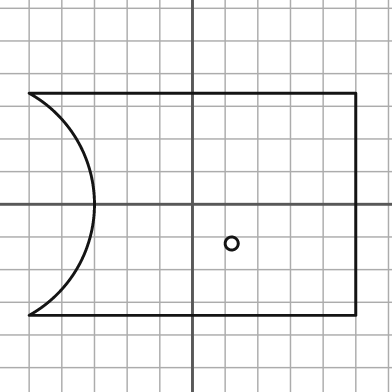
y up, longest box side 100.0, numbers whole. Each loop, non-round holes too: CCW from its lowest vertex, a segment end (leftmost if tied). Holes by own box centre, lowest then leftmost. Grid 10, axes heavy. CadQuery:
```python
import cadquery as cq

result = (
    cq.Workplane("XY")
    .moveTo(-50.0, -34.0)
    .lineTo(50.0, -34.0)
    .lineTo(50.0, 34.0)
    .lineTo(-50.0, 34.0)
    .threePointArc((-30.0, 0.0), (-50.0, -34.0))
    .close()
    .moveTo(12.0, -12.0)
    .circle(2.0)
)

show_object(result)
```